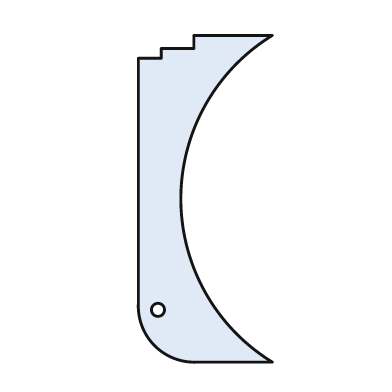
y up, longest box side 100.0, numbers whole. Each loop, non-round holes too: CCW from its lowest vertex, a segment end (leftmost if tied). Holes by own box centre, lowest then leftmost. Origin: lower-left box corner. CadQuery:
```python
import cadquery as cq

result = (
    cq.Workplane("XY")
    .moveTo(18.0, 0.0)
    .lineTo(41.0, 0.0)
    .threePointArc((13.0, 50.0), (41.0, 100.0))
    .lineTo(17.0, 100.0)
    .lineTo(17.0, 96.0)
    .lineTo(7.0, 96.0)
    .lineTo(7.0, 93.0)
    .lineTo(0.0, 93.0)
    .lineTo(0.0, 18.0)
    .threePointArc((5.0, 5.0), (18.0, 0.0))
    .close()
    .moveTo(6.0, 16.0)
    .circle(2.0)
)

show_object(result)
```